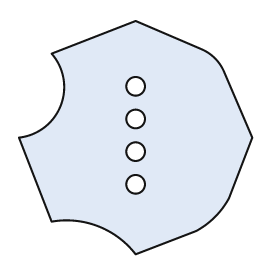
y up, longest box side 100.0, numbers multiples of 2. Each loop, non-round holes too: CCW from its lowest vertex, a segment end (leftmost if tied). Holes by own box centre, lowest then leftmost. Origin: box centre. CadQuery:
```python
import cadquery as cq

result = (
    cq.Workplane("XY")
    .moveTo(0.0, -50.0)
    .lineTo(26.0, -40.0)
    .threePointArc((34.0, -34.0), (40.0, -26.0))
    .lineTo(50.0, 0.0)
    .lineTo(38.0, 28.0)
    .threePointArc((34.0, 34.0), (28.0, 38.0))
    .lineTo(0.0, 50.0)
    .lineTo(-36.0, 36.0)
    .threePointArc((-32.0, 14.0), (-50.0, 0.0))
    .lineTo(-36.0, -36.0)
    .threePointArc((-16.0, -38.0), (0.0, -50.0))
    .close()
    .moveTo(0.0, -20.0)
    .circle(4.0)
    .moveTo(0.0, -6.0)
    .circle(4.0)
    .moveTo(0.0, 8.0)
    .circle(4.0)
    .moveTo(0.0, 22.0)
    .circle(4.0)
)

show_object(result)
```